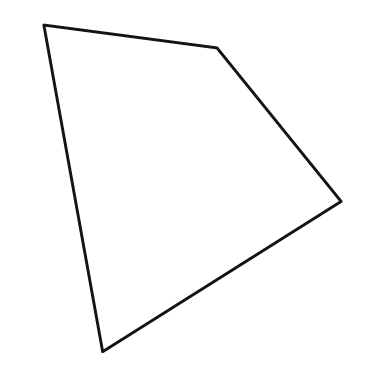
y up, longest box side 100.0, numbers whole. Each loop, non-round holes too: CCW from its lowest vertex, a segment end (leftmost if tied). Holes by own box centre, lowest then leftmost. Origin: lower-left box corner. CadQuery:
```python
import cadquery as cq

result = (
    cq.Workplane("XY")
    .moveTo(18.0, 0.0)
    .lineTo(91.0, 46.0)
    .lineTo(53.0, 93.0)
    .lineTo(0.0, 100.0)
    .close()
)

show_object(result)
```